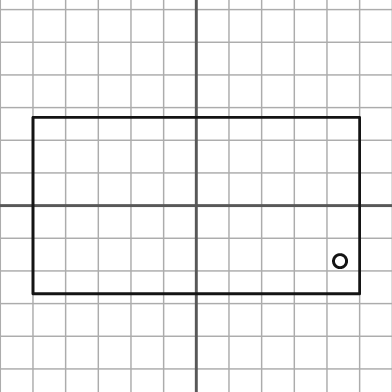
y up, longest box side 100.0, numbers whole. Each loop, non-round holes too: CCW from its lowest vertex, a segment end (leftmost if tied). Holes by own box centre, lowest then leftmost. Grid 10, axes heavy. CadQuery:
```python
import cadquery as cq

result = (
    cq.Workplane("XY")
    .moveTo(-50.0, -27.0)
    .lineTo(50.0, -27.0)
    .lineTo(50.0, 27.0)
    .lineTo(-50.0, 27.0)
    .close()
    .moveTo(44.0, -17.0)
    .circle(2.0)
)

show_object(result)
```